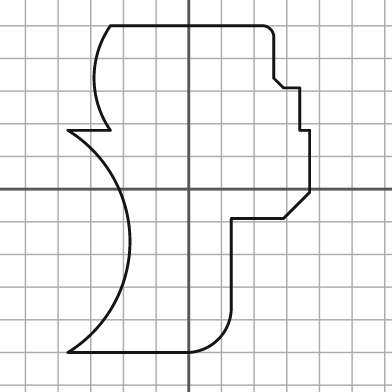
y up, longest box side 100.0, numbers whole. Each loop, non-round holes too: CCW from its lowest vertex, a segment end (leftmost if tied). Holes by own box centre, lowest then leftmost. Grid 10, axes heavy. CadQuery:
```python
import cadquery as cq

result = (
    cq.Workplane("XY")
    .moveTo(-37.0, -50.0)
    .lineTo(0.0, -50.0)
    .threePointArc((9.0, -46.0), (13.0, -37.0))
    .lineTo(13.0, -9.0)
    .lineTo(29.0, -9.0)
    .lineTo(37.0, -1.0)
    .lineTo(37.0, 18.0)
    .lineTo(34.0, 18.0)
    .lineTo(34.0, 31.0)
    .lineTo(29.0, 31.0)
    .lineTo(26.0, 34.0)
    .lineTo(26.0, 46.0)
    .threePointArc((25.0, 49.0), (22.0, 50.0))
    .lineTo(-24.0, 50.0)
    .threePointArc((-29.0, 34.0), (-24.0, 18.0))
    .lineTo(-37.0, 18.0)
    .threePointArc((-18.0, -16.0), (-37.0, -50.0))
    .close()
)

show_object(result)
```